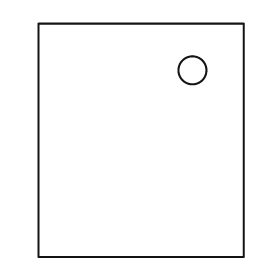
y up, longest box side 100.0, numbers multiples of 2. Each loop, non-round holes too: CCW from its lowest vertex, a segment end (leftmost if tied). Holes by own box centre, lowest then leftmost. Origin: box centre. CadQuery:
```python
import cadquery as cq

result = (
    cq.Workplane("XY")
    .moveTo(-44.0, -50.0)
    .lineTo(44.0, -50.0)
    .lineTo(44.0, 50.0)
    .lineTo(-44.0, 50.0)
    .close()
    .moveTo(22.0, 30.0)
    .circle(6.0)
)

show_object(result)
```